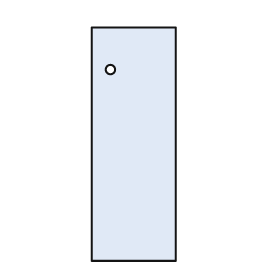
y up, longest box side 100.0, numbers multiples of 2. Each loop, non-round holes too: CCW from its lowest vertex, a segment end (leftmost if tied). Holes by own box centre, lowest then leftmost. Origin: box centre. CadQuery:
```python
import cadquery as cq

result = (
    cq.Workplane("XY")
    .moveTo(-18.0, -50.0)
    .lineTo(18.0, -50.0)
    .lineTo(18.0, 50.0)
    .lineTo(-18.0, 50.0)
    .close()
    .moveTo(-10.0, 32.0)
    .circle(2.0)
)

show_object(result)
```